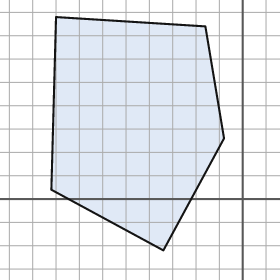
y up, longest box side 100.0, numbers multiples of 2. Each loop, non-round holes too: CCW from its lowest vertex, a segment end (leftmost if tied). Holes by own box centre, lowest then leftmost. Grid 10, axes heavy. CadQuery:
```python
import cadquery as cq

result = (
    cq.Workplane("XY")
    .moveTo(-34.0, -22.0)
    .lineTo(-8.0, 26.0)
    .lineTo(-16.0, 74.0)
    .lineTo(-80.0, 78.0)
    .lineTo(-82.0, 4.0)
    .close()
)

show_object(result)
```